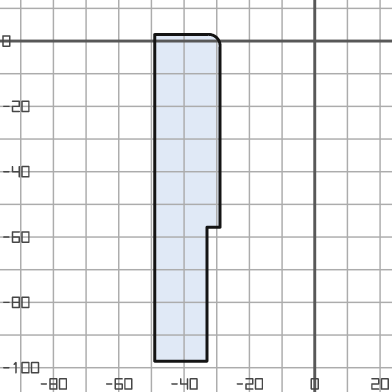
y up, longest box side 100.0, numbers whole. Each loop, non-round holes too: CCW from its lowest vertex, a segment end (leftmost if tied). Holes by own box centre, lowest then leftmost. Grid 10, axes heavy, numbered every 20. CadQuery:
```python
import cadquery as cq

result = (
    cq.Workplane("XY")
    .moveTo(-49.0, -98.0)
    .lineTo(-33.0, -98.0)
    .lineTo(-33.0, -57.0)
    .lineTo(-29.0, -57.0)
    .lineTo(-29.0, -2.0)
    .threePointArc((-30.0, 1.0), (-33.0, 2.0))
    .lineTo(-49.0, 2.0)
    .close()
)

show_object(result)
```